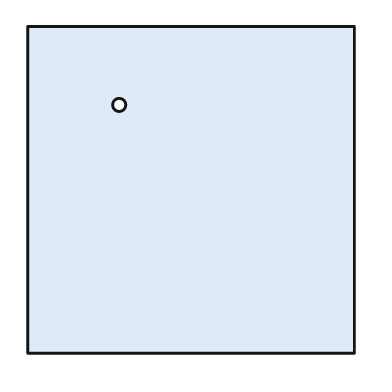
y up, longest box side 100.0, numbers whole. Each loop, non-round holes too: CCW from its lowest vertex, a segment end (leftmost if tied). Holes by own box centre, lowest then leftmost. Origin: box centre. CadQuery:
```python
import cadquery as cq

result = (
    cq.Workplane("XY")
    .moveTo(-50.0, -50.0)
    .lineTo(50.0, -50.0)
    .lineTo(50.0, 50.0)
    .lineTo(-50.0, 50.0)
    .close()
    .moveTo(-22.0, 26.0)
    .circle(2.0)
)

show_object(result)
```